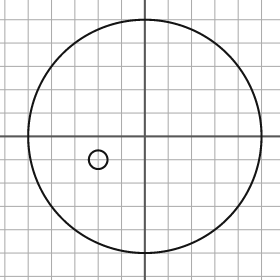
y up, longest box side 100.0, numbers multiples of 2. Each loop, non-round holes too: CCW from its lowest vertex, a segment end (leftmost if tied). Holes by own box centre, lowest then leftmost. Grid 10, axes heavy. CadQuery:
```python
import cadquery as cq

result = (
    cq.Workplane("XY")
    .moveTo(0.0, 0.0)
    .circle(50.0)
    .moveTo(-20.0, -10.0)
    .circle(4.0)
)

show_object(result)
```